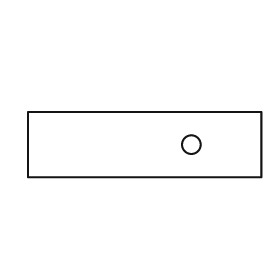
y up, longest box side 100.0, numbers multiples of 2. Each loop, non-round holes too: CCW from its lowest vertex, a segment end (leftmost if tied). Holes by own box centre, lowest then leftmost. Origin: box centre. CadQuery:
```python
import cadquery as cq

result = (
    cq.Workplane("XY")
    .moveTo(-50.0, -14.0)
    .lineTo(50.0, -14.0)
    .lineTo(50.0, 14.0)
    .lineTo(-50.0, 14.0)
    .close()
    .moveTo(20.0, 0.0)
    .circle(4.0)
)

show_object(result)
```